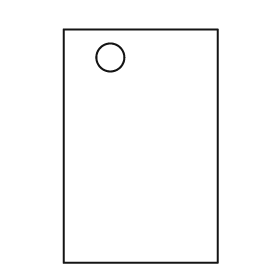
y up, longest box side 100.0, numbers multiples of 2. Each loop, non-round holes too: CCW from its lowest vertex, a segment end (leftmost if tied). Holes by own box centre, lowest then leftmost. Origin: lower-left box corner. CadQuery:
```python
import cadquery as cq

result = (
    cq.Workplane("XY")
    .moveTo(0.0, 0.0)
    .lineTo(66.0, 0.0)
    .lineTo(66.0, 100.0)
    .lineTo(0.0, 100.0)
    .close()
    .moveTo(20.0, 88.0)
    .circle(6.0)
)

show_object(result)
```